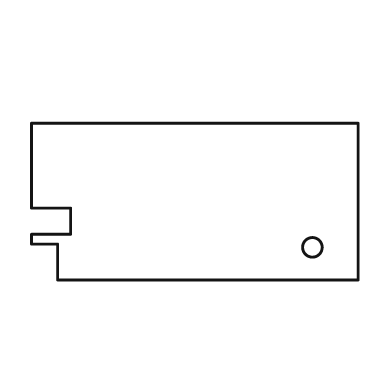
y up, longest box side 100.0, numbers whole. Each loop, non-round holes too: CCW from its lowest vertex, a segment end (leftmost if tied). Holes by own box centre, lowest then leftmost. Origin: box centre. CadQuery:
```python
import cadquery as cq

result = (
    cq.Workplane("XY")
    .moveTo(-42.0, -24.0)
    .lineTo(50.0, -24.0)
    .lineTo(50.0, 24.0)
    .lineTo(-50.0, 24.0)
    .lineTo(-50.0, -2.0)
    .lineTo(-38.0, -2.0)
    .lineTo(-38.0, -10.0)
    .lineTo(-50.0, -10.0)
    .lineTo(-50.0, -13.0)
    .lineTo(-42.0, -13.0)
    .close()
    .moveTo(36.0, -14.0)
    .circle(3.0)
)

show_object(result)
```